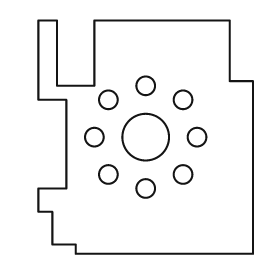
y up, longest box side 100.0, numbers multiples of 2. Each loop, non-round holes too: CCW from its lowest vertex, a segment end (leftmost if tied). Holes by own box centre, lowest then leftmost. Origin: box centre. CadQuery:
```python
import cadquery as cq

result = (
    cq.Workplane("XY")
    .moveTo(-30.0, -50.0)
    .lineTo(46.0, -50.0)
    .lineTo(46.0, 24.0)
    .lineTo(36.0, 24.0)
    .lineTo(36.0, 50.0)
    .lineTo(-22.0, 50.0)
    .lineTo(-22.0, 22.0)
    .lineTo(-38.0, 22.0)
    .lineTo(-38.0, 50.0)
    .lineTo(-46.0, 50.0)
    .lineTo(-46.0, 16.0)
    .lineTo(-34.0, 16.0)
    .lineTo(-34.0, -22.0)
    .lineTo(-46.0, -22.0)
    .lineTo(-46.0, -32.0)
    .lineTo(-40.0, -32.0)
    .lineTo(-40.0, -46.0)
    .lineTo(-30.0, -46.0)
    .close()
    .moveTo(0.0, -22.0)
    .circle(4.0)
    .moveTo(-16.0, -16.0)
    .circle(4.0)
    .moveTo(16.0, -16.0)
    .circle(4.0)
    .moveTo(-22.0, 0.0)
    .circle(4.0)
    .moveTo(0.0, 0.0)
    .circle(10.0)
    .moveTo(22.0, 0.0)
    .circle(4.0)
    .moveTo(-16.0, 16.0)
    .circle(4.0)
    .moveTo(16.0, 16.0)
    .circle(4.0)
    .moveTo(0.0, 22.0)
    .circle(4.0)
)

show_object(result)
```